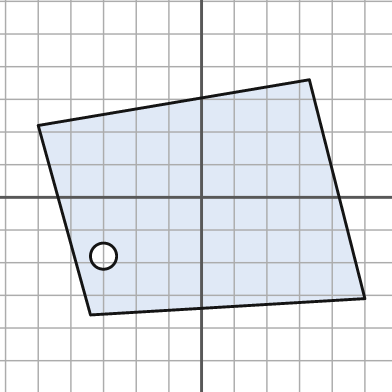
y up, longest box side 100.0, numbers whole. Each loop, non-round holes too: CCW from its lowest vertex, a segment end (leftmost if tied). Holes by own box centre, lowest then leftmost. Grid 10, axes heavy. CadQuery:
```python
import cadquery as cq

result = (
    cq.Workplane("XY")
    .moveTo(-34.0, -36.0)
    .lineTo(50.0, -31.0)
    .lineTo(33.0, 36.0)
    .lineTo(-50.0, 22.0)
    .close()
    .moveTo(-30.0, -18.0)
    .circle(4.0)
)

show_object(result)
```